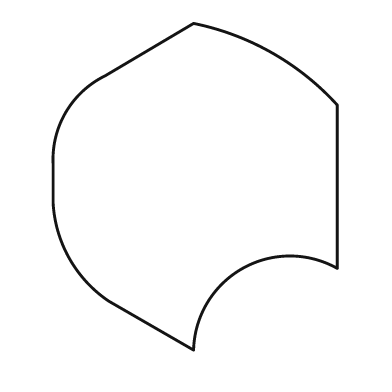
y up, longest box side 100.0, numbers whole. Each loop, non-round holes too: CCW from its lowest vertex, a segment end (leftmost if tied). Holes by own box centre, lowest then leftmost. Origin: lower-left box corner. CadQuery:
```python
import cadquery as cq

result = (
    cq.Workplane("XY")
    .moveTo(43.0, 0.0)
    .threePointArc((58.0, 25.0), (87.0, 25.0))
    .lineTo(87.0, 75.0)
    .threePointArc((67.0, 91.0), (43.0, 100.0))
    .lineTo(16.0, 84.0)
    .threePointArc((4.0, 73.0), (0.0, 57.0))
    .lineTo(0.0, 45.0)
    .threePointArc((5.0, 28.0), (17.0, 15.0))
    .close()
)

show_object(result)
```